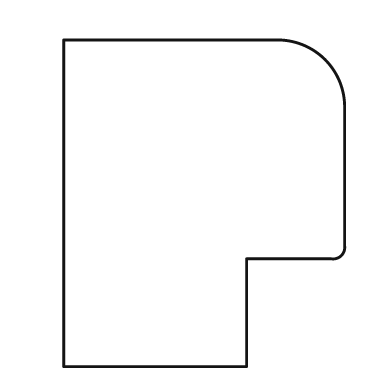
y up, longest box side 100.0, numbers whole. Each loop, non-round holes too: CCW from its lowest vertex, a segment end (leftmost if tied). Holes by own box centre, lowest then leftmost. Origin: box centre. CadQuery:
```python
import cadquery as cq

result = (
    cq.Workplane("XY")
    .moveTo(-43.0, -50.0)
    .lineTo(13.0, -50.0)
    .lineTo(13.0, -17.0)
    .lineTo(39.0, -17.0)
    .threePointArc((42.0, -16.0), (43.0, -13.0))
    .lineTo(43.0, 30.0)
    .threePointArc((37.0, 44.0), (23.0, 50.0))
    .lineTo(-43.0, 50.0)
    .close()
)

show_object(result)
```